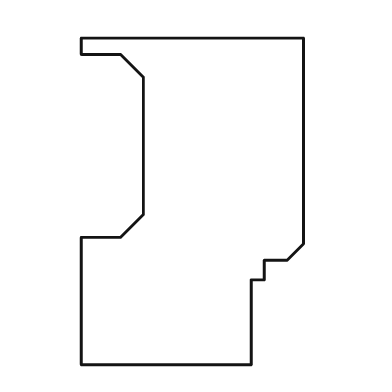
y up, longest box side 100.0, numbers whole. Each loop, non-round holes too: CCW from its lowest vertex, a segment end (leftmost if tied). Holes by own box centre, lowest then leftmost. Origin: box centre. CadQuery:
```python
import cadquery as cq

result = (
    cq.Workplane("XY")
    .moveTo(-34.0, -50.0)
    .lineTo(18.0, -50.0)
    .lineTo(18.0, -24.0)
    .lineTo(22.0, -24.0)
    .lineTo(22.0, -18.0)
    .lineTo(29.0, -18.0)
    .lineTo(34.0, -13.0)
    .lineTo(34.0, 50.0)
    .lineTo(-34.0, 50.0)
    .lineTo(-34.0, 45.0)
    .lineTo(-22.0, 45.0)
    .lineTo(-15.0, 38.0)
    .lineTo(-15.0, -4.0)
    .lineTo(-22.0, -11.0)
    .lineTo(-34.0, -11.0)
    .close()
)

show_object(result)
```